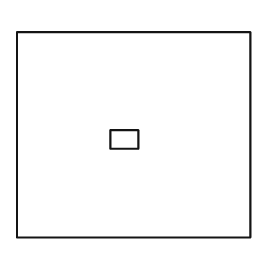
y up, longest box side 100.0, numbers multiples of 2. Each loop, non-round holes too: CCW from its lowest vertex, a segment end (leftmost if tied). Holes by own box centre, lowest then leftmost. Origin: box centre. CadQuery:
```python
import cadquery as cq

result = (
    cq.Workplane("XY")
    .moveTo(-50.0, -44.0)
    .lineTo(50.0, -44.0)
    .lineTo(50.0, 44.0)
    .lineTo(-50.0, 44.0)
    .close()
    .moveTo(-10.0, -6.0)
    .lineTo(2.0, -6.0)
    .lineTo(2.0, 2.0)
    .lineTo(-10.0, 2.0)
    .close()
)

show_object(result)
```